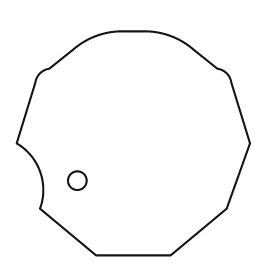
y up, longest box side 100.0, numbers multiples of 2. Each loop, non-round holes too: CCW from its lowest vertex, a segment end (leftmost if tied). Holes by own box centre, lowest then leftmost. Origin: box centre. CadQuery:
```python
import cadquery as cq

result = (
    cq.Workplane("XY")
    .moveTo(-16.0, -48.0)
    .lineTo(16.0, -48.0)
    .lineTo(40.0, -28.0)
    .lineTo(50.0, 0.0)
    .lineTo(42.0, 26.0)
    .threePointArc((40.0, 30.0), (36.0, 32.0))
    .lineTo(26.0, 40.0)
    .threePointArc((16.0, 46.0), (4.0, 48.0))
    .lineTo(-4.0, 48.0)
    .threePointArc((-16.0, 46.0), (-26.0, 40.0))
    .lineTo(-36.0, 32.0)
    .threePointArc((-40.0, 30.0), (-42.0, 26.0))
    .lineTo(-50.0, 0.0)
    .threePointArc((-40.0, -12.0), (-40.0, -28.0))
    .close()
    .moveTo(-24.0, -16.0)
    .circle(4.0)
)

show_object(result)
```